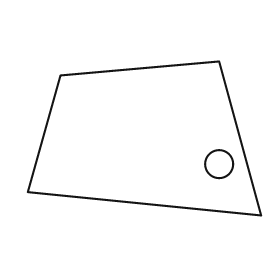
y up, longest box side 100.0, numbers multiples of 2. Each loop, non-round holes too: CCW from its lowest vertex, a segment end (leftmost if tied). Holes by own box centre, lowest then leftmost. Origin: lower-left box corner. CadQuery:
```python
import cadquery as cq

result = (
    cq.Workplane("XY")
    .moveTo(100.0, 0.0)
    .lineTo(82.0, 66.0)
    .lineTo(14.0, 60.0)
    .lineTo(0.0, 10.0)
    .close()
    .moveTo(82.0, 22.0)
    .circle(6.0)
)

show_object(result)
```